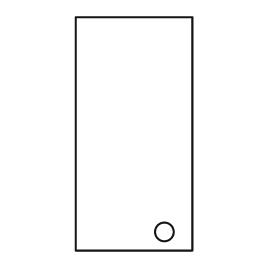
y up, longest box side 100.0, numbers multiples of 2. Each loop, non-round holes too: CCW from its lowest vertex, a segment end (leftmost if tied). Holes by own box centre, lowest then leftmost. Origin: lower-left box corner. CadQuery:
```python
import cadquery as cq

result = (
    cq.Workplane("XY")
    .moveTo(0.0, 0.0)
    .lineTo(50.0, 0.0)
    .lineTo(50.0, 100.0)
    .lineTo(0.0, 100.0)
    .close()
    .moveTo(38.0, 8.0)
    .circle(4.0)
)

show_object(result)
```